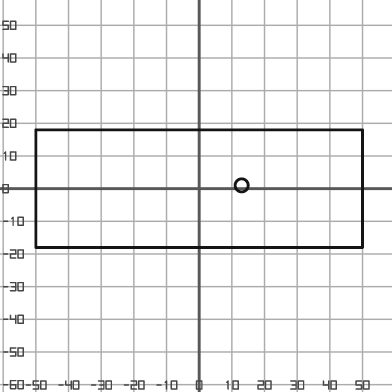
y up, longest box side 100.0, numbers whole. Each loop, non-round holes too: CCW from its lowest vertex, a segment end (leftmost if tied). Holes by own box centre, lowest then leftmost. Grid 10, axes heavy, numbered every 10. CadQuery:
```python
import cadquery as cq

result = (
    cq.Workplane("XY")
    .moveTo(-50.0, -18.0)
    .lineTo(50.0, -18.0)
    .lineTo(50.0, 18.0)
    .lineTo(-50.0, 18.0)
    .close()
    .moveTo(13.0, 1.0)
    .circle(2.0)
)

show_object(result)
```